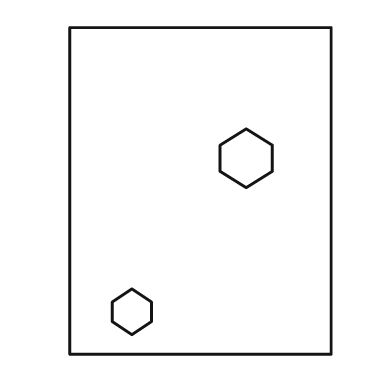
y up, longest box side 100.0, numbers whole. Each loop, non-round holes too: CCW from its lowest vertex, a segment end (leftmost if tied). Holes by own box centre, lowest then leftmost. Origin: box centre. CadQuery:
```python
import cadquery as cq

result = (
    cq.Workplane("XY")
    .moveTo(-40.0, -50.0)
    .lineTo(40.0, -50.0)
    .lineTo(40.0, 50.0)
    .lineTo(-40.0, 50.0)
    .close()
    .moveTo(-21.0, -44.0)
    .lineTo(-15.0, -40.0)
    .lineTo(-15.0, -34.0)
    .lineTo(-21.0, -30.0)
    .lineTo(-27.0, -34.0)
    .lineTo(-27.0, -40.0)
    .close()
    .moveTo(14.0, 1.0)
    .lineTo(22.0, 6.0)
    .lineTo(22.0, 14.0)
    .lineTo(14.0, 19.0)
    .lineTo(6.0, 14.0)
    .lineTo(6.0, 6.0)
    .close()
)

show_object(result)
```